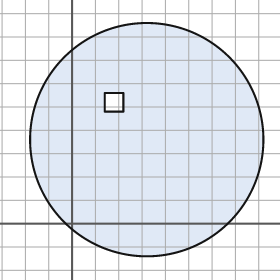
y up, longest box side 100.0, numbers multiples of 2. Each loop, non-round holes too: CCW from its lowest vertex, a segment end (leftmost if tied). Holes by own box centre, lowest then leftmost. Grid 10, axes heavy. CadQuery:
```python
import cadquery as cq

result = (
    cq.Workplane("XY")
    .moveTo(32.0, 36.0)
    .circle(50.0)
    .moveTo(14.0, 48.0)
    .lineTo(22.0, 48.0)
    .lineTo(22.0, 56.0)
    .lineTo(14.0, 56.0)
    .close()
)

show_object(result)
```